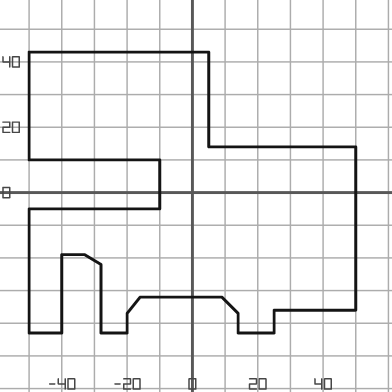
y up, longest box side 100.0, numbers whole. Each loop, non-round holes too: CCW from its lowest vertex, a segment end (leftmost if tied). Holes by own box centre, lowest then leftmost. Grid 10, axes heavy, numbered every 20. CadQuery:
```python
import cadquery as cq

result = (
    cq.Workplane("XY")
    .moveTo(-50.0, -43.0)
    .lineTo(-40.0, -43.0)
    .lineTo(-40.0, -19.0)
    .lineTo(-33.0, -19.0)
    .lineTo(-28.0, -22.0)
    .lineTo(-28.0, -43.0)
    .lineTo(-20.0, -43.0)
    .lineTo(-20.0, -37.0)
    .lineTo(-16.0, -32.0)
    .lineTo(9.0, -32.0)
    .lineTo(14.0, -37.0)
    .lineTo(14.0, -43.0)
    .lineTo(25.0, -43.0)
    .lineTo(25.0, -36.0)
    .lineTo(50.0, -36.0)
    .lineTo(50.0, 14.0)
    .lineTo(5.0, 14.0)
    .lineTo(5.0, 43.0)
    .lineTo(-50.0, 43.0)
    .lineTo(-50.0, 10.0)
    .lineTo(-10.0, 10.0)
    .lineTo(-10.0, -5.0)
    .lineTo(-50.0, -5.0)
    .close()
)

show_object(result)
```